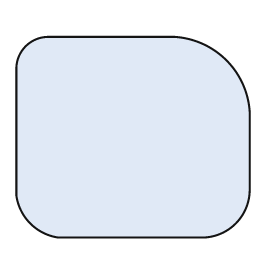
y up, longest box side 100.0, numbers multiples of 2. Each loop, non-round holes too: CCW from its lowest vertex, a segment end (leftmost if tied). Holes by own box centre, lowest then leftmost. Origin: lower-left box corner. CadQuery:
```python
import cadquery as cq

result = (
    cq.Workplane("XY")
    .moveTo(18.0, 0.0)
    .lineTo(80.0, 0.0)
    .threePointArc((94.0, 6.0), (100.0, 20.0))
    .lineTo(100.0, 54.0)
    .threePointArc((90.0, 76.0), (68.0, 86.0))
    .lineTo(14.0, 86.0)
    .threePointArc((4.0, 82.0), (0.0, 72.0))
    .lineTo(0.0, 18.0)
    .threePointArc((6.0, 6.0), (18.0, 0.0))
    .close()
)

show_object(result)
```